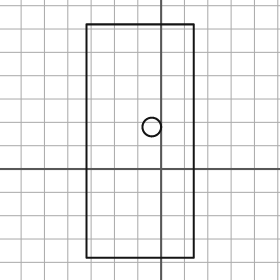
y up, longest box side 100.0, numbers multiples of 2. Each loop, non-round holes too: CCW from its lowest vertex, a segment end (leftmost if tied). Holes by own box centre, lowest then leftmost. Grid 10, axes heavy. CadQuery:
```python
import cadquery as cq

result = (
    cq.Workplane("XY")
    .moveTo(-32.0, -38.0)
    .lineTo(14.0, -38.0)
    .lineTo(14.0, 62.0)
    .lineTo(-32.0, 62.0)
    .close()
    .moveTo(-4.0, 18.0)
    .circle(4.0)
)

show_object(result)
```